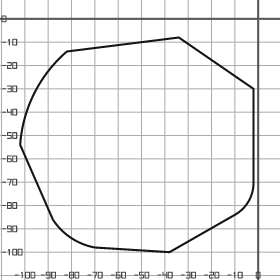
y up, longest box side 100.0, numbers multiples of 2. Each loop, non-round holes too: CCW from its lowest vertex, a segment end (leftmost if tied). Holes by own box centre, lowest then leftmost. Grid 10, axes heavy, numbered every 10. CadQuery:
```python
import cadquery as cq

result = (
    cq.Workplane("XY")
    .moveTo(-38.0, -100.0)
    .lineTo(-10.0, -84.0)
    .threePointArc((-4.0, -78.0), (-2.0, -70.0))
    .lineTo(-2.0, -30.0)
    .lineTo(-34.0, -8.0)
    .lineTo(-82.0, -14.0)
    .threePointArc((-96.0, -32.0), (-102.0, -54.0))
    .lineTo(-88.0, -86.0)
    .threePointArc((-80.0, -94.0), (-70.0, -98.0))
    .close()
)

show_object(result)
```